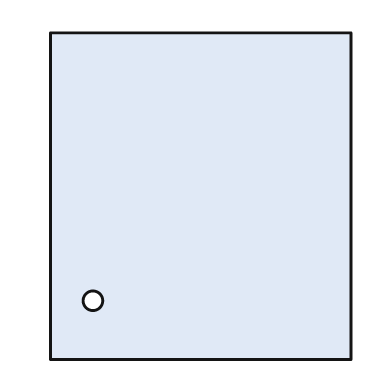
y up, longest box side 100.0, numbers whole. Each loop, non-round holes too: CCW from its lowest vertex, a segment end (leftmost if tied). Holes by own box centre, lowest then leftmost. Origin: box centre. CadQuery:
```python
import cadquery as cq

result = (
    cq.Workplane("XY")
    .moveTo(-46.0, -50.0)
    .lineTo(46.0, -50.0)
    .lineTo(46.0, 50.0)
    .lineTo(-46.0, 50.0)
    .close()
    .moveTo(-33.0, -32.0)
    .circle(3.0)
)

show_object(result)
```